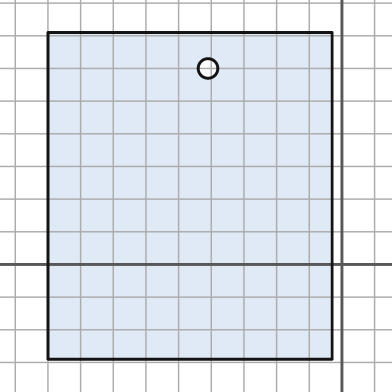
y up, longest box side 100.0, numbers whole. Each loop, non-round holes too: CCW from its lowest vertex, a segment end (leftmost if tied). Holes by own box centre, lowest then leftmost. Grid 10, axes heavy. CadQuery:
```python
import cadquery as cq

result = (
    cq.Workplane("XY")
    .moveTo(-90.0, -29.0)
    .lineTo(-3.0, -29.0)
    .lineTo(-3.0, 71.0)
    .lineTo(-90.0, 71.0)
    .close()
    .moveTo(-41.0, 60.0)
    .circle(3.0)
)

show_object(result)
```